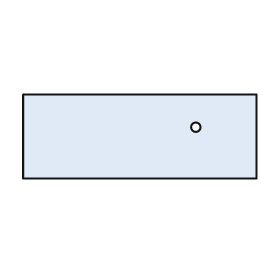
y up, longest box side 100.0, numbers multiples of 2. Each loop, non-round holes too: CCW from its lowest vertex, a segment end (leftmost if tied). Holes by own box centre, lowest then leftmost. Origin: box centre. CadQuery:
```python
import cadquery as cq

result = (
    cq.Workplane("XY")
    .moveTo(-50.0, -18.0)
    .lineTo(50.0, -18.0)
    .lineTo(50.0, 18.0)
    .lineTo(-50.0, 18.0)
    .close()
    .moveTo(24.0, 4.0)
    .circle(2.0)
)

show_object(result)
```